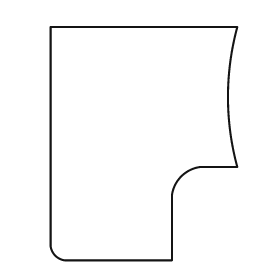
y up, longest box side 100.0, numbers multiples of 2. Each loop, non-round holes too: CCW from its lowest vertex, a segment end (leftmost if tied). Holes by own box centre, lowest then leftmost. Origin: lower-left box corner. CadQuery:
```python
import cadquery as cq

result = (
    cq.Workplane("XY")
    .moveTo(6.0, 0.0)
    .lineTo(52.0, 0.0)
    .lineTo(52.0, 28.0)
    .threePointArc((56.0, 36.0), (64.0, 40.0))
    .lineTo(80.0, 40.0)
    .threePointArc((76.0, 70.0), (80.0, 100.0))
    .lineTo(0.0, 100.0)
    .lineTo(0.0, 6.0)
    .threePointArc((2.0, 2.0), (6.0, 0.0))
    .close()
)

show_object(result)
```